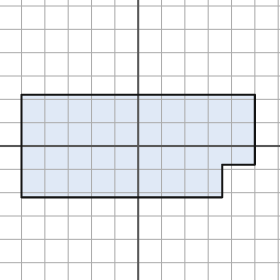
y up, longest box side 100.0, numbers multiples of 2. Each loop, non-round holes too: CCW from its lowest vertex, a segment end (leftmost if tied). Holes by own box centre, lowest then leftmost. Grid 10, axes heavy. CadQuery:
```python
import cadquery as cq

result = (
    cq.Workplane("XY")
    .moveTo(-50.0, -22.0)
    .lineTo(36.0, -22.0)
    .lineTo(36.0, -8.0)
    .lineTo(50.0, -8.0)
    .lineTo(50.0, 22.0)
    .lineTo(-50.0, 22.0)
    .close()
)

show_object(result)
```